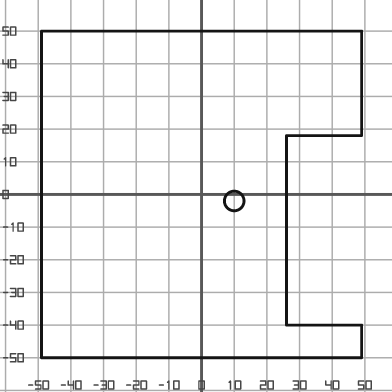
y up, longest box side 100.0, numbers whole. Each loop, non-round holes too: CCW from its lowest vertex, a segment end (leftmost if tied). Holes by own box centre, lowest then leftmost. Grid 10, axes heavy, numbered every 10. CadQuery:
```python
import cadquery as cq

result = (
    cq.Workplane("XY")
    .moveTo(-49.0, -50.0)
    .lineTo(49.0, -50.0)
    .lineTo(49.0, -40.0)
    .lineTo(26.0, -40.0)
    .lineTo(26.0, 18.0)
    .lineTo(49.0, 18.0)
    .lineTo(49.0, 50.0)
    .lineTo(-49.0, 50.0)
    .close()
    .moveTo(10.0, -2.0)
    .circle(3.0)
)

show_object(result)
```